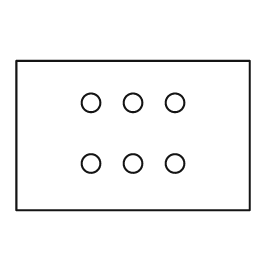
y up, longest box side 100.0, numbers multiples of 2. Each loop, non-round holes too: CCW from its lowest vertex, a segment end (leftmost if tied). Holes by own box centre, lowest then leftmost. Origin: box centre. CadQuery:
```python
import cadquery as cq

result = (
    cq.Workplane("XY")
    .moveTo(-50.0, -32.0)
    .lineTo(50.0, -32.0)
    .lineTo(50.0, 32.0)
    .lineTo(-50.0, 32.0)
    .close()
    .moveTo(-18.0, -12.0)
    .circle(4.0)
    .moveTo(0.0, -12.0)
    .circle(4.0)
    .moveTo(18.0, -12.0)
    .circle(4.0)
    .moveTo(-18.0, 14.0)
    .circle(4.0)
    .moveTo(0.0, 14.0)
    .circle(4.0)
    .moveTo(18.0, 14.0)
    .circle(4.0)
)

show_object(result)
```